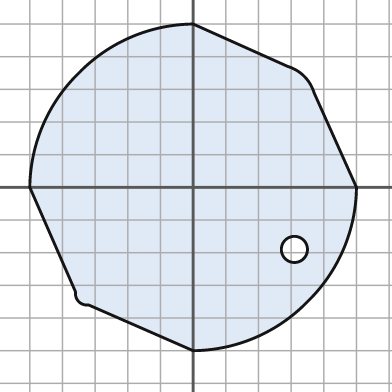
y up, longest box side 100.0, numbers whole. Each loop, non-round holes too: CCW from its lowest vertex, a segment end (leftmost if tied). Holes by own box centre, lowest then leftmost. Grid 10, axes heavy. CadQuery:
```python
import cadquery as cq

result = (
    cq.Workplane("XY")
    .moveTo(0.0, -50.0)
    .threePointArc((19.0, -46.0), (35.0, -35.0))
    .threePointArc((46.0, -19.0), (50.0, 0.0))
    .lineTo(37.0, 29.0)
    .threePointArc((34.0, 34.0), (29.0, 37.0))
    .lineTo(0.0, 50.0)
    .threePointArc((-19.0, 46.0), (-35.0, 35.0))
    .threePointArc((-46.0, 19.0), (-50.0, 0.0))
    .lineTo(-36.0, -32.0)
    .threePointArc((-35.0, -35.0), (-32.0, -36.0))
    .close()
    .moveTo(31.0, -19.0)
    .circle(4.0)
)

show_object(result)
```